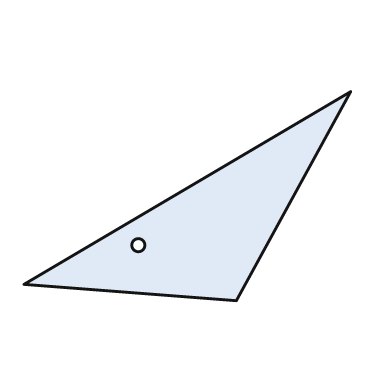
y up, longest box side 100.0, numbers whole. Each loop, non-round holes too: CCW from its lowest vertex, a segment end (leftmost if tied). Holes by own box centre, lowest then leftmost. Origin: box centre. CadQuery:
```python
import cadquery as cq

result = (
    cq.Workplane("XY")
    .moveTo(15.0, -32.0)
    .lineTo(50.0, 32.0)
    .lineTo(-50.0, -27.0)
    .close()
    .moveTo(-15.0, -15.0)
    .circle(2.0)
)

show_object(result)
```